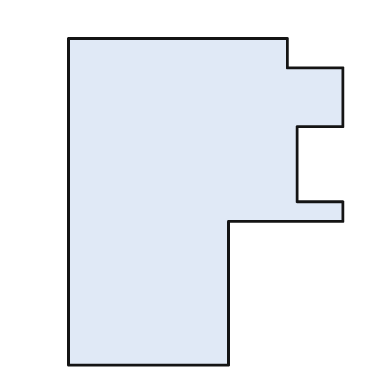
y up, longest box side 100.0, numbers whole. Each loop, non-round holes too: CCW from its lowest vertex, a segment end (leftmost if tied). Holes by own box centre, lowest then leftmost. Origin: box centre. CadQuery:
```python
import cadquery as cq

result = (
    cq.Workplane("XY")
    .moveTo(-42.0, -50.0)
    .lineTo(7.0, -50.0)
    .lineTo(7.0, -6.0)
    .lineTo(42.0, -6.0)
    .lineTo(42.0, 0.0)
    .lineTo(28.0, 0.0)
    .lineTo(28.0, 23.0)
    .lineTo(42.0, 23.0)
    .lineTo(42.0, 41.0)
    .lineTo(25.0, 41.0)
    .lineTo(25.0, 50.0)
    .lineTo(-42.0, 50.0)
    .close()
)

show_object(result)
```